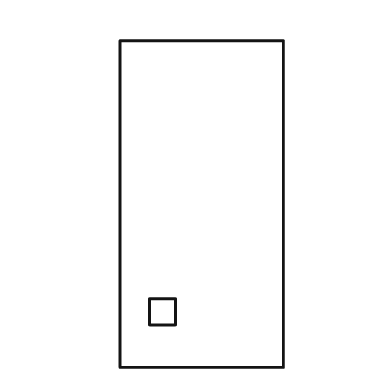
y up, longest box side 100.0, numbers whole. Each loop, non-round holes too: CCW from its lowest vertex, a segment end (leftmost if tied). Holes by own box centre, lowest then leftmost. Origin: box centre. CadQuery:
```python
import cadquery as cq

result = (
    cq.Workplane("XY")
    .moveTo(-25.0, -50.0)
    .lineTo(25.0, -50.0)
    .lineTo(25.0, 50.0)
    .lineTo(-25.0, 50.0)
    .close()
    .moveTo(-16.0, -37.0)
    .lineTo(-8.0, -37.0)
    .lineTo(-8.0, -29.0)
    .lineTo(-16.0, -29.0)
    .close()
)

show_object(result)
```